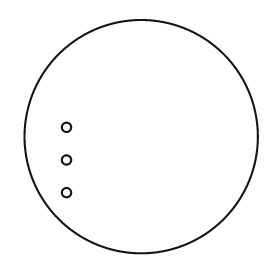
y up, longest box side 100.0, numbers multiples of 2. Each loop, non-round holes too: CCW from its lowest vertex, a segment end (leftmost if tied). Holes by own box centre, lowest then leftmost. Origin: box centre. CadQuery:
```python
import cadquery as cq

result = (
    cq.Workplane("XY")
    .moveTo(0.0, 0.0)
    .circle(50.0)
    .moveTo(-32.0, -24.0)
    .circle(2.0)
    .moveTo(-32.0, -10.0)
    .circle(2.0)
    .moveTo(-32.0, 4.0)
    .circle(2.0)
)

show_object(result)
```